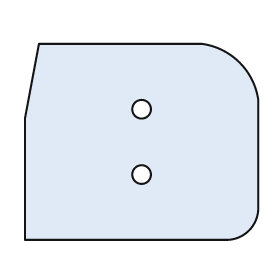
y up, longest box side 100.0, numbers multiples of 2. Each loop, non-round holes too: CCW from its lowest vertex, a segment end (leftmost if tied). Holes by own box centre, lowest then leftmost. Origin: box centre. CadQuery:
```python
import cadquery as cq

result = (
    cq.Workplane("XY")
    .moveTo(-50.0, -42.0)
    .lineTo(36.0, -42.0)
    .threePointArc((46.0, -38.0), (50.0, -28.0))
    .lineTo(50.0, 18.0)
    .threePointArc((42.0, 34.0), (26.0, 42.0))
    .lineTo(-44.0, 42.0)
    .lineTo(-50.0, 10.0)
    .close()
    .moveTo(0.0, -14.0)
    .circle(4.0)
    .moveTo(0.0, 14.0)
    .circle(4.0)
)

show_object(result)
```